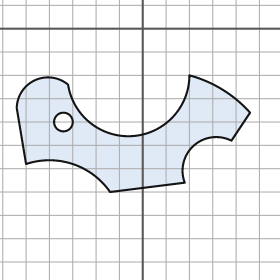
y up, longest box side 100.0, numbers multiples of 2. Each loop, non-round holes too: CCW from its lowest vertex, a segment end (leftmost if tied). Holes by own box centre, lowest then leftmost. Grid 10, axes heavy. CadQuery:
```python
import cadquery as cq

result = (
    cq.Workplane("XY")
    .moveTo(-14.0, -70.0)
    .lineTo(18.0, -66.0)
    .threePointArc((22.0, -50.0), (38.0, -48.0))
    .lineTo(46.0, -36.0)
    .threePointArc((34.0, -26.0), (20.0, -20.0))
    .threePointArc((-4.0, -46.0), (-32.0, -24.0))
    .threePointArc((-46.0, -22.0), (-54.0, -34.0))
    .lineTo(-50.0, -58.0)
    .threePointArc((-30.0, -58.0), (-14.0, -70.0))
    .close()
    .moveTo(-34.0, -40.0)
    .circle(4.0)
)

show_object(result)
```